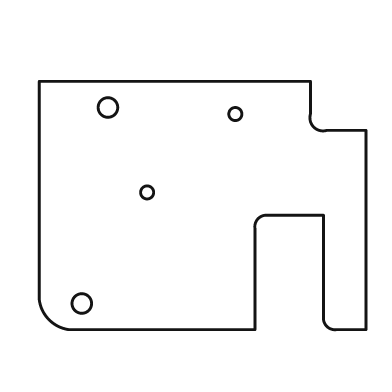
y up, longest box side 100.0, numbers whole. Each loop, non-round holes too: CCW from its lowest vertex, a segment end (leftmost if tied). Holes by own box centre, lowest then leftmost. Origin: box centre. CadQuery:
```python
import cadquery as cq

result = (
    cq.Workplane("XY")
    .moveTo(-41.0, -38.0)
    .lineTo(16.0, -38.0)
    .lineTo(16.0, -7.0)
    .threePointArc((17.0, -4.0), (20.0, -3.0))
    .lineTo(37.0, -3.0)
    .lineTo(37.0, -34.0)
    .threePointArc((38.0, -37.0), (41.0, -38.0))
    .lineTo(50.0, -38.0)
    .lineTo(50.0, 23.0)
    .lineTo(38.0, 23.0)
    .threePointArc((34.0, 24.0), (33.0, 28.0))
    .lineTo(33.0, 38.0)
    .lineTo(-50.0, 38.0)
    .lineTo(-50.0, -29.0)
    .threePointArc((-47.0, -35.0), (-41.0, -38.0))
    .close()
    .moveTo(-37.0, -30.0)
    .circle(3.0)
    .moveTo(-17.0, 4.0)
    .circle(2.0)
    .moveTo(10.0, 28.0)
    .circle(2.0)
    .moveTo(-29.0, 30.0)
    .circle(3.0)
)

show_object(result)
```